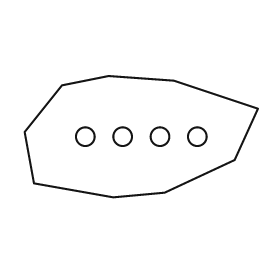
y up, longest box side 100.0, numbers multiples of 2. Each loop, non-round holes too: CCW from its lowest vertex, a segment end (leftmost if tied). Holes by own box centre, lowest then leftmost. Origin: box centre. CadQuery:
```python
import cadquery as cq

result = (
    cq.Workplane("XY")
    .moveTo(-12.0, -26.0)
    .lineTo(10.0, -24.0)
    .lineTo(40.0, -10.0)
    .lineTo(50.0, 12.0)
    .lineTo(14.0, 24.0)
    .lineTo(-14.0, 26.0)
    .lineTo(-34.0, 22.0)
    .lineTo(-50.0, 2.0)
    .lineTo(-46.0, -20.0)
    .close()
    .moveTo(-24.0, 0.0)
    .circle(4.0)
    .moveTo(-8.0, 0.0)
    .circle(4.0)
    .moveTo(8.0, 0.0)
    .circle(4.0)
    .moveTo(24.0, 0.0)
    .circle(4.0)
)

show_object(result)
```